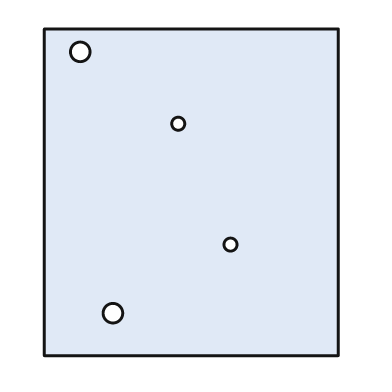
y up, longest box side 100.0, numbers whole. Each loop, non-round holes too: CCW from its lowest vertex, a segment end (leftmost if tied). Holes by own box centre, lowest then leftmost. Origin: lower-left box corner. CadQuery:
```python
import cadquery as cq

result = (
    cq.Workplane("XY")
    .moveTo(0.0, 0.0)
    .lineTo(90.0, 0.0)
    .lineTo(90.0, 100.0)
    .lineTo(0.0, 100.0)
    .close()
    .moveTo(21.0, 13.0)
    .circle(3.0)
    .moveTo(57.0, 34.0)
    .circle(2.0)
    .moveTo(41.0, 71.0)
    .circle(2.0)
    .moveTo(11.0, 93.0)
    .circle(3.0)
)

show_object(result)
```